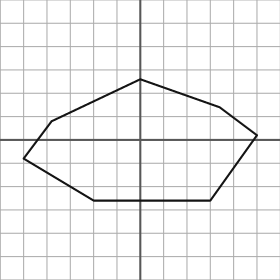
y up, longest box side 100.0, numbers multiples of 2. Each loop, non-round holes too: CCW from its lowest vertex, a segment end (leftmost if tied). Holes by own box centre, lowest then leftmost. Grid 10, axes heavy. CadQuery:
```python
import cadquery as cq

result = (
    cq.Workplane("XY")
    .moveTo(-20.0, -26.0)
    .lineTo(30.0, -26.0)
    .lineTo(50.0, 2.0)
    .lineTo(34.0, 14.0)
    .lineTo(0.0, 26.0)
    .lineTo(-38.0, 8.0)
    .lineTo(-50.0, -8.0)
    .close()
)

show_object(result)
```